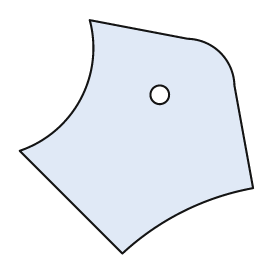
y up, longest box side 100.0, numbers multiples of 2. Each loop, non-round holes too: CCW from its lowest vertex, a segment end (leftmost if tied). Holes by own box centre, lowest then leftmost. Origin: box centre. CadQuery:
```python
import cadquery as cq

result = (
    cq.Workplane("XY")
    .moveTo(-6.0, -50.0)
    .threePointArc((20.0, -32.0), (50.0, -22.0))
    .lineTo(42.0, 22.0)
    .threePointArc((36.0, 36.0), (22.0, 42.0))
    .lineTo(-20.0, 50.0)
    .threePointArc((-24.0, 16.0), (-50.0, -6.0))
    .close()
    .moveTo(10.0, 18.0)
    .circle(4.0)
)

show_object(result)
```